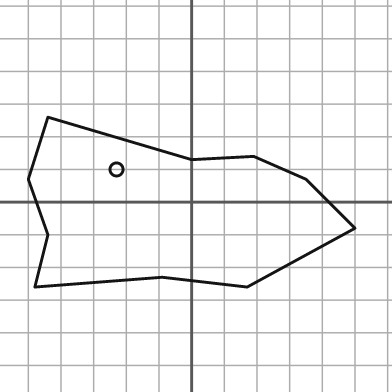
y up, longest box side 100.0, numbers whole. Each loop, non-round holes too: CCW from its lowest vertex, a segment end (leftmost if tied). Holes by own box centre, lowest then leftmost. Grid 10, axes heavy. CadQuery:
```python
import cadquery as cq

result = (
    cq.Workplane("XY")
    .moveTo(-48.0, -26.0)
    .lineTo(-9.0, -23.0)
    .lineTo(17.0, -26.0)
    .lineTo(50.0, -8.0)
    .lineTo(35.0, 7.0)
    .lineTo(19.0, 14.0)
    .lineTo(0.0, 13.0)
    .lineTo(-44.0, 26.0)
    .lineTo(-50.0, 7.0)
    .lineTo(-44.0, -10.0)
    .close()
    .moveTo(-23.0, 10.0)
    .circle(2.0)
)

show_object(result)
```